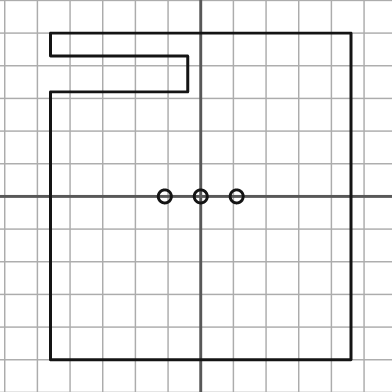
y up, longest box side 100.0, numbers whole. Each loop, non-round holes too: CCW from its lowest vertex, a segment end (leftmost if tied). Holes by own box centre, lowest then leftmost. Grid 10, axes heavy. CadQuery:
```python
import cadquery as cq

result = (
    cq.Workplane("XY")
    .moveTo(-46.0, -50.0)
    .lineTo(46.0, -50.0)
    .lineTo(46.0, 50.0)
    .lineTo(-46.0, 50.0)
    .lineTo(-46.0, 43.0)
    .lineTo(-4.0, 43.0)
    .lineTo(-4.0, 32.0)
    .lineTo(-46.0, 32.0)
    .close()
    .moveTo(-11.0, 0.0)
    .circle(2.0)
    .moveTo(0.0, 0.0)
    .circle(2.0)
    .moveTo(11.0, 0.0)
    .circle(2.0)
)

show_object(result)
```